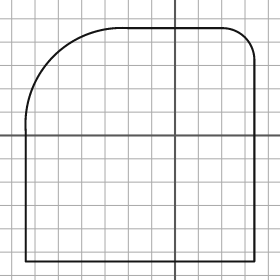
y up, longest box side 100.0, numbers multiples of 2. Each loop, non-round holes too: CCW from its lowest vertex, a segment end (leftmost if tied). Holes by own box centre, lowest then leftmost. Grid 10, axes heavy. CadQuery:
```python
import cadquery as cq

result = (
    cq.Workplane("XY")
    .moveTo(-64.0, -54.0)
    .lineTo(34.0, -54.0)
    .lineTo(34.0, 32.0)
    .threePointArc((30.0, 42.0), (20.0, 46.0))
    .lineTo(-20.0, 46.0)
    .threePointArc((-52.0, 34.0), (-64.0, 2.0))
    .close()
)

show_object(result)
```